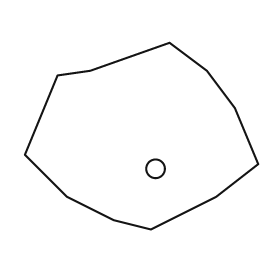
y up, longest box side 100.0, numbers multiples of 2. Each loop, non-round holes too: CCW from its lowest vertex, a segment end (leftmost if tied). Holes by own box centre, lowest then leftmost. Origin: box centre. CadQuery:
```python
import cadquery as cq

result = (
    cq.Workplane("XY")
    .moveTo(4.0, -40.0)
    .lineTo(32.0, -26.0)
    .lineTo(50.0, -12.0)
    .lineTo(40.0, 12.0)
    .lineTo(28.0, 28.0)
    .lineTo(12.0, 40.0)
    .lineTo(-22.0, 28.0)
    .lineTo(-36.0, 26.0)
    .lineTo(-50.0, -8.0)
    .lineTo(-32.0, -26.0)
    .lineTo(-12.0, -36.0)
    .close()
    .moveTo(6.0, -14.0)
    .circle(4.0)
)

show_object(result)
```